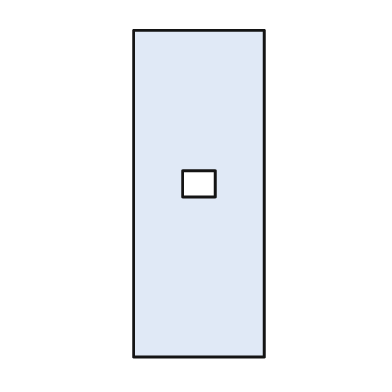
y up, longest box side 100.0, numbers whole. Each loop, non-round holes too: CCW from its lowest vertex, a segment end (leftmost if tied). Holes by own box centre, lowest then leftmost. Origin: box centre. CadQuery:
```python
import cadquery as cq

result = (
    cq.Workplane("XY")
    .moveTo(-20.0, -50.0)
    .lineTo(20.0, -50.0)
    .lineTo(20.0, 50.0)
    .lineTo(-20.0, 50.0)
    .close()
    .moveTo(-5.0, -1.0)
    .lineTo(5.0, -1.0)
    .lineTo(5.0, 7.0)
    .lineTo(-5.0, 7.0)
    .close()
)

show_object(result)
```